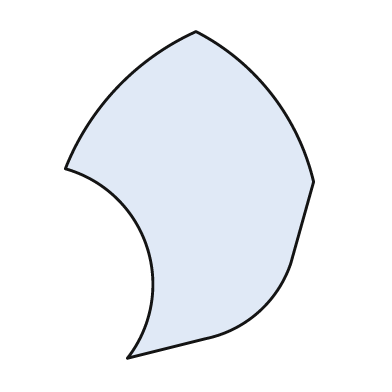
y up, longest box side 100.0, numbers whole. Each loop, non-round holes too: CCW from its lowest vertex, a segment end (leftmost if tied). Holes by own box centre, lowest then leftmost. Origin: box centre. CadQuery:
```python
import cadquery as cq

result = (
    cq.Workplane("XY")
    .moveTo(-19.0, -50.0)
    .lineTo(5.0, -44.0)
    .threePointArc((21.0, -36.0), (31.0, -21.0))
    .lineTo(38.0, 4.0)
    .threePointArc((25.0, 31.0), (2.0, 50.0))
    .threePointArc((-22.0, 33.0), (-38.0, 8.0))
    .threePointArc((-13.0, -16.0), (-19.0, -50.0))
    .close()
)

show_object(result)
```